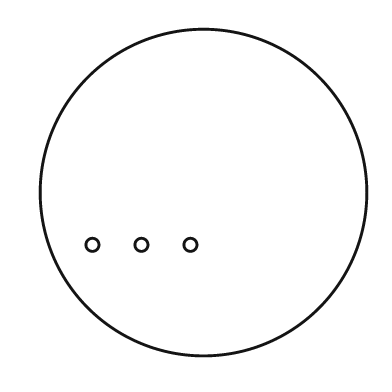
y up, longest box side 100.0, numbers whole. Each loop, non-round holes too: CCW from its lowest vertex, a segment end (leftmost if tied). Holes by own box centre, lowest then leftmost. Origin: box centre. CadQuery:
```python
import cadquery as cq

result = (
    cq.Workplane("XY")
    .moveTo(0.0, 0.0)
    .circle(50.0)
    .moveTo(-34.0, -16.0)
    .circle(2.0)
    .moveTo(-19.0, -16.0)
    .circle(2.0)
    .moveTo(-4.0, -16.0)
    .circle(2.0)
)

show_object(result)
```